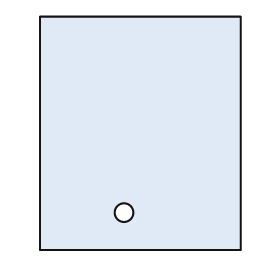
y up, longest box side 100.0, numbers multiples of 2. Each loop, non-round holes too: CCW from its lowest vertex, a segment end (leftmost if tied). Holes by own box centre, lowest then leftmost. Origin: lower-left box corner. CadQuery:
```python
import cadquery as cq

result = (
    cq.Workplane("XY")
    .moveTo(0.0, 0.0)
    .lineTo(86.0, 0.0)
    .lineTo(86.0, 100.0)
    .lineTo(0.0, 100.0)
    .close()
    .moveTo(36.0, 16.0)
    .circle(4.0)
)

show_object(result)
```